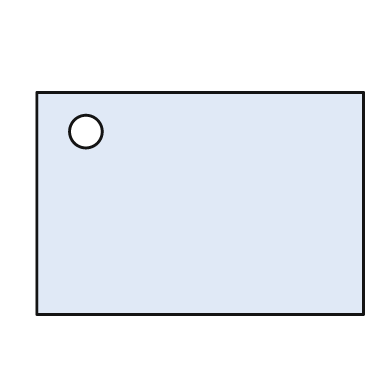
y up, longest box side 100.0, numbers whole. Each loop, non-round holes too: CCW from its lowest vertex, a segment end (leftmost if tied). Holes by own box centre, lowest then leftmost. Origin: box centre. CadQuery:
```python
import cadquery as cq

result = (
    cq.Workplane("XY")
    .moveTo(-50.0, -34.0)
    .lineTo(50.0, -34.0)
    .lineTo(50.0, 34.0)
    .lineTo(-50.0, 34.0)
    .close()
    .moveTo(-35.0, 22.0)
    .circle(5.0)
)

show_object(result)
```